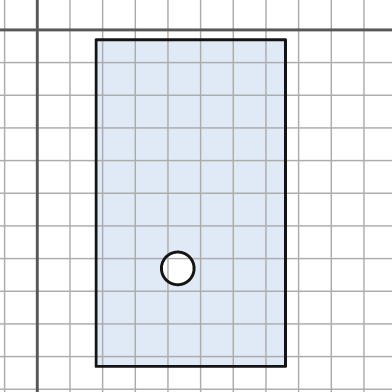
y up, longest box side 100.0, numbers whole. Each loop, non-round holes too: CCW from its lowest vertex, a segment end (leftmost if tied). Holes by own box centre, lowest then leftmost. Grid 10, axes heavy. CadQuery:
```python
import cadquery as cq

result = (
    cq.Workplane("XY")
    .moveTo(18.0, -103.0)
    .lineTo(76.0, -103.0)
    .lineTo(76.0, -3.0)
    .lineTo(18.0, -3.0)
    .close()
    .moveTo(43.0, -73.0)
    .circle(5.0)
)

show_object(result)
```